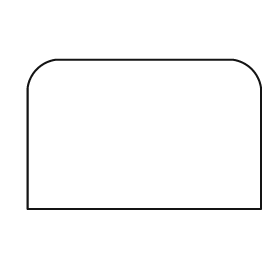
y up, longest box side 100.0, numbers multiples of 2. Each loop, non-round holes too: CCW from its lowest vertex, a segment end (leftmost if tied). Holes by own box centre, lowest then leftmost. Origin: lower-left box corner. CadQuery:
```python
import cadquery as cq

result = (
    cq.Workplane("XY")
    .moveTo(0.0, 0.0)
    .lineTo(100.0, 0.0)
    .lineTo(100.0, 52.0)
    .threePointArc((96.0, 60.0), (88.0, 64.0))
    .lineTo(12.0, 64.0)
    .threePointArc((4.0, 60.0), (0.0, 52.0))
    .close()
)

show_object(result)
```